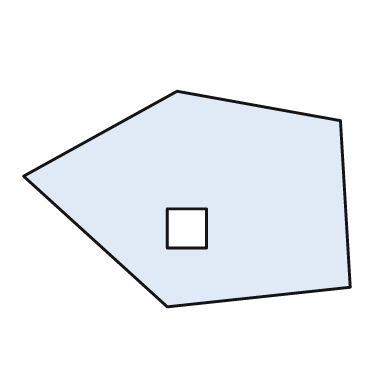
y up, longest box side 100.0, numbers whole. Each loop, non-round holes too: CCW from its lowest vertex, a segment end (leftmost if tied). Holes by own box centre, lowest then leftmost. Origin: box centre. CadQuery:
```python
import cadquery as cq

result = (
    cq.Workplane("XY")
    .moveTo(-6.0, -33.0)
    .lineTo(50.0, -27.0)
    .lineTo(47.0, 24.0)
    .lineTo(-3.0, 33.0)
    .lineTo(-50.0, 7.0)
    .close()
    .moveTo(-6.0, -15.0)
    .lineTo(6.0, -15.0)
    .lineTo(6.0, -3.0)
    .lineTo(-6.0, -3.0)
    .close()
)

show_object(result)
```